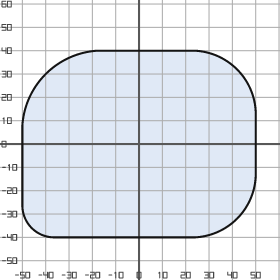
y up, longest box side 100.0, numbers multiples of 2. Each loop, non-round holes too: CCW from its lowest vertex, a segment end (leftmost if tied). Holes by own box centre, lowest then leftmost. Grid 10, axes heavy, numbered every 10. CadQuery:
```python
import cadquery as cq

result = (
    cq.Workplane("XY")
    .moveTo(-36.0, -40.0)
    .lineTo(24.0, -40.0)
    .threePointArc((42.0, -32.0), (50.0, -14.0))
    .lineTo(50.0, 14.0)
    .threePointArc((42.0, 32.0), (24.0, 40.0))
    .lineTo(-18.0, 40.0)
    .threePointArc((-40.0, 30.0), (-50.0, 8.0))
    .lineTo(-50.0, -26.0)
    .threePointArc((-46.0, -36.0), (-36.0, -40.0))
    .close()
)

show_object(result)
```